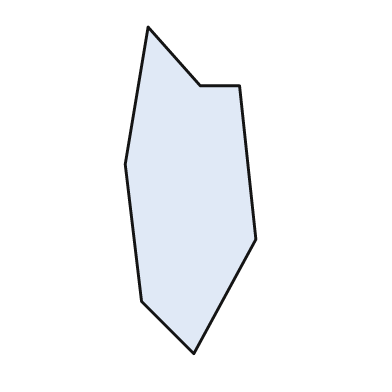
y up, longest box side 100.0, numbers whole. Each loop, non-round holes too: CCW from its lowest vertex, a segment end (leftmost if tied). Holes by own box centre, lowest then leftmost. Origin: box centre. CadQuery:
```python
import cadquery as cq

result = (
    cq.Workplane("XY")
    .moveTo(1.0, -50.0)
    .lineTo(20.0, -15.0)
    .lineTo(15.0, 32.0)
    .lineTo(3.0, 32.0)
    .lineTo(-13.0, 50.0)
    .lineTo(-20.0, 8.0)
    .lineTo(-15.0, -34.0)
    .close()
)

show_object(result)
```